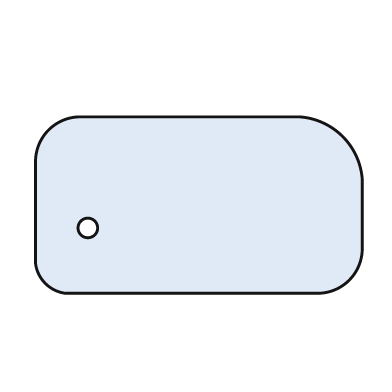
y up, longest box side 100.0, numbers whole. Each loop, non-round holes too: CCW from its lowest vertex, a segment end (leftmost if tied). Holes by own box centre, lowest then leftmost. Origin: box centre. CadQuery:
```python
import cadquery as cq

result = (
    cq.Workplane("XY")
    .moveTo(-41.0, -27.0)
    .lineTo(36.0, -27.0)
    .threePointArc((46.0, -23.0), (50.0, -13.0))
    .lineTo(50.0, 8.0)
    .threePointArc((44.0, 21.0), (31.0, 27.0))
    .lineTo(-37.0, 27.0)
    .threePointArc((-46.0, 23.0), (-50.0, 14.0))
    .lineTo(-50.0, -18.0)
    .threePointArc((-47.0, -24.0), (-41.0, -27.0))
    .close()
    .moveTo(-34.0, -7.0)
    .circle(3.0)
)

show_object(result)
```